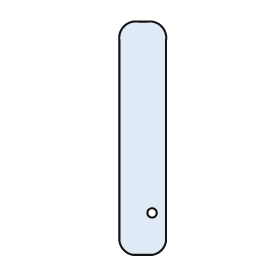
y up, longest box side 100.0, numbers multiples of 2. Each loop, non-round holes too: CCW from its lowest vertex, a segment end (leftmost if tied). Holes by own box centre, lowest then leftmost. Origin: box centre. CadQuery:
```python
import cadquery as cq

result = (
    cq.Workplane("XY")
    .moveTo(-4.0, -50.0)
    .lineTo(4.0, -50.0)
    .threePointArc((8.0, -48.0), (10.0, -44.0))
    .lineTo(10.0, 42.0)
    .threePointArc((8.0, 48.0), (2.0, 50.0))
    .lineTo(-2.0, 50.0)
    .threePointArc((-8.0, 48.0), (-10.0, 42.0))
    .lineTo(-10.0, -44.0)
    .threePointArc((-8.0, -48.0), (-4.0, -50.0))
    .close()
    .moveTo(4.0, -32.0)
    .circle(2.0)
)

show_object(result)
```